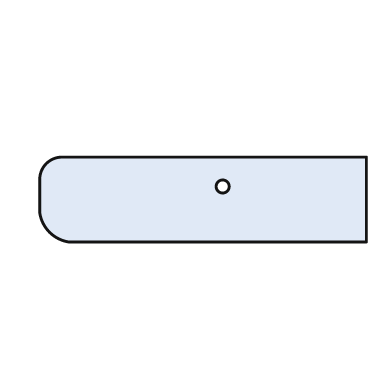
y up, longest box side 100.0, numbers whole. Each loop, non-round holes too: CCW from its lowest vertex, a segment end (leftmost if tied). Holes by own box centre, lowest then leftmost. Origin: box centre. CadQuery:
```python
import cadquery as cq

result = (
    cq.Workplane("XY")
    .moveTo(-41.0, -13.0)
    .lineTo(50.0, -13.0)
    .lineTo(50.0, 13.0)
    .lineTo(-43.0, 13.0)
    .threePointArc((-48.0, 11.0), (-50.0, 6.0))
    .lineTo(-50.0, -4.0)
    .threePointArc((-47.0, -10.0), (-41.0, -13.0))
    .close()
    .moveTo(6.0, 4.0)
    .circle(2.0)
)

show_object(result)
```